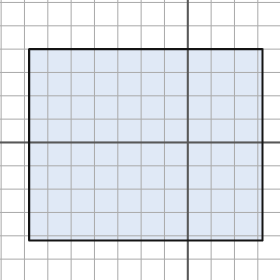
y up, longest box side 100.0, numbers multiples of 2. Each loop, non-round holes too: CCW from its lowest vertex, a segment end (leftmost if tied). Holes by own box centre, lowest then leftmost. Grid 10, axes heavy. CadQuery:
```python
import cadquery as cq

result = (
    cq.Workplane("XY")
    .moveTo(-68.0, -42.0)
    .lineTo(32.0, -42.0)
    .lineTo(32.0, 40.0)
    .lineTo(-68.0, 40.0)
    .close()
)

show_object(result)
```